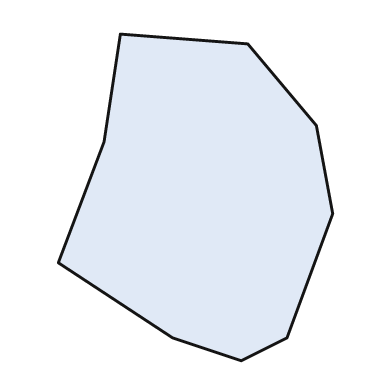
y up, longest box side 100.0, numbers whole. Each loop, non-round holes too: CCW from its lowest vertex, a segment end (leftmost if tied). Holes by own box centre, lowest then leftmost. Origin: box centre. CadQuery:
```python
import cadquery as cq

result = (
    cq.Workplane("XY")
    .moveTo(14.0, -50.0)
    .lineTo(28.0, -43.0)
    .lineTo(42.0, -5.0)
    .lineTo(37.0, 22.0)
    .lineTo(16.0, 47.0)
    .lineTo(-23.0, 50.0)
    .lineTo(-28.0, 17.0)
    .lineTo(-42.0, -20.0)
    .lineTo(-7.0, -43.0)
    .close()
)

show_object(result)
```